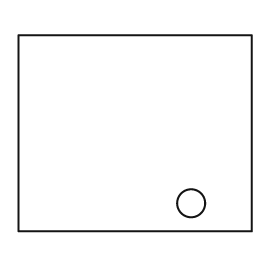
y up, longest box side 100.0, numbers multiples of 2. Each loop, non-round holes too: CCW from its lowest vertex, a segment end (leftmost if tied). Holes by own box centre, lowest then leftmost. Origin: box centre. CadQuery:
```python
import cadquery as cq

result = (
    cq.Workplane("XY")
    .moveTo(-50.0, -42.0)
    .lineTo(50.0, -42.0)
    .lineTo(50.0, 42.0)
    .lineTo(-50.0, 42.0)
    .close()
    .moveTo(24.0, -30.0)
    .circle(6.0)
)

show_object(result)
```